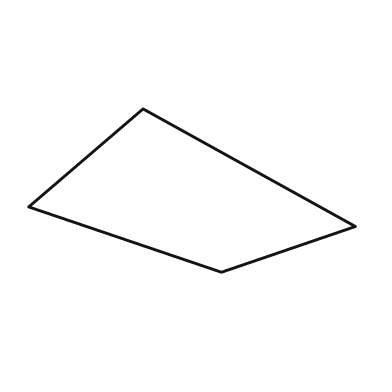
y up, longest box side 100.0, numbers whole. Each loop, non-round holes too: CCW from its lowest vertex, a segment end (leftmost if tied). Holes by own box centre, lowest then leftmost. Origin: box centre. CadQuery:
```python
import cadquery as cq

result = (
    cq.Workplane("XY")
    .moveTo(9.0, -25.0)
    .lineTo(50.0, -11.0)
    .lineTo(-15.0, 25.0)
    .lineTo(-50.0, -5.0)
    .close()
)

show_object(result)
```